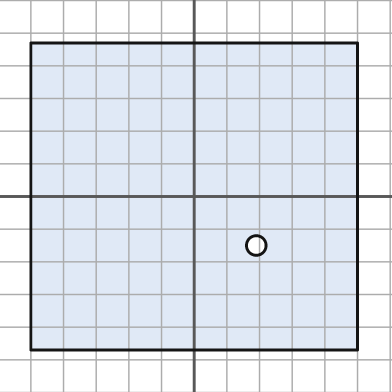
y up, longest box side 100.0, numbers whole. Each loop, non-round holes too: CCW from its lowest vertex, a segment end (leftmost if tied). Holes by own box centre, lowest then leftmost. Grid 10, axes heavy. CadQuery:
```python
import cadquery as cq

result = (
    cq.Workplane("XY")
    .moveTo(-50.0, -47.0)
    .lineTo(50.0, -47.0)
    .lineTo(50.0, 47.0)
    .lineTo(-50.0, 47.0)
    .close()
    .moveTo(19.0, -15.0)
    .circle(3.0)
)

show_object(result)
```